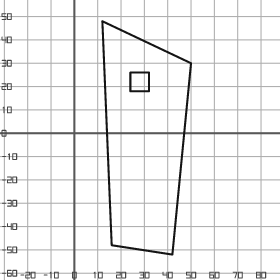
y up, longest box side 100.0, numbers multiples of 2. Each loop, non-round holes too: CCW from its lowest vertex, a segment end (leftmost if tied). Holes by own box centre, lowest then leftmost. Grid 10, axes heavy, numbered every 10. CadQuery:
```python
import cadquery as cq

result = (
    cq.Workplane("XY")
    .moveTo(42.0, -52.0)
    .lineTo(50.0, 30.0)
    .lineTo(12.0, 48.0)
    .lineTo(16.0, -48.0)
    .close()
    .moveTo(24.0, 18.0)
    .lineTo(32.0, 18.0)
    .lineTo(32.0, 26.0)
    .lineTo(24.0, 26.0)
    .close()
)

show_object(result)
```